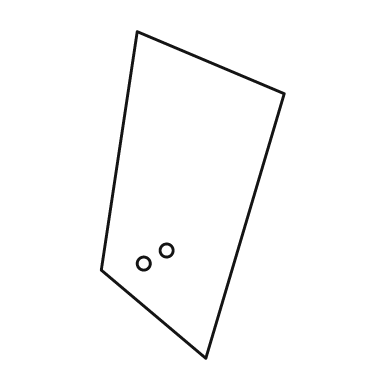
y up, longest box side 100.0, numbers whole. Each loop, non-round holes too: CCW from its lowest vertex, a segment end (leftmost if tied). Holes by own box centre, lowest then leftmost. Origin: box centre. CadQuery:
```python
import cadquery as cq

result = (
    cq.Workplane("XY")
    .moveTo(4.0, -50.0)
    .lineTo(28.0, 31.0)
    .lineTo(-17.0, 50.0)
    .lineTo(-28.0, -23.0)
    .close()
    .moveTo(-15.0, -21.0)
    .circle(2.0)
    .moveTo(-8.0, -17.0)
    .circle(2.0)
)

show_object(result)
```